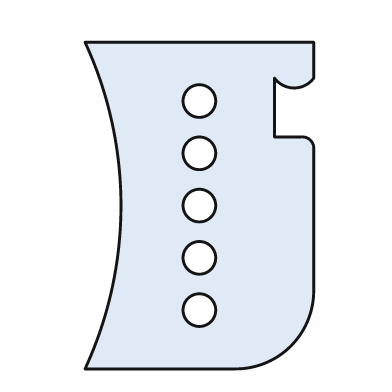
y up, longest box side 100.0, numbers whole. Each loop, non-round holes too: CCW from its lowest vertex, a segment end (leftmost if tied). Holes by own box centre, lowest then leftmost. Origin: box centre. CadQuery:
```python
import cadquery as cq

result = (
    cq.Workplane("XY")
    .moveTo(-35.0, -50.0)
    .lineTo(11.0, -50.0)
    .threePointArc((28.0, -43.0), (35.0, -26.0))
    .lineTo(35.0, 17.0)
    .threePointArc((34.0, 20.0), (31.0, 21.0))
    .lineTo(23.0, 21.0)
    .lineTo(23.0, 39.0)
    .threePointArc((29.0, 36.0), (35.0, 39.0))
    .lineTo(35.0, 50.0)
    .lineTo(-35.0, 50.0)
    .threePointArc((-24.0, 0.0), (-35.0, -50.0))
    .close()
    .moveTo(0.0, -32.0)
    .circle(5.0)
    .moveTo(0.0, -16.0)
    .circle(5.0)
    .moveTo(0.0, 0.0)
    .circle(5.0)
    .moveTo(0.0, 16.0)
    .circle(5.0)
    .moveTo(0.0, 32.0)
    .circle(5.0)
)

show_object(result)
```